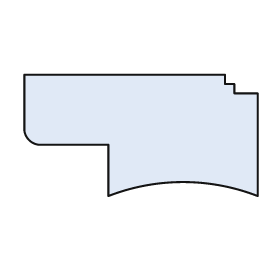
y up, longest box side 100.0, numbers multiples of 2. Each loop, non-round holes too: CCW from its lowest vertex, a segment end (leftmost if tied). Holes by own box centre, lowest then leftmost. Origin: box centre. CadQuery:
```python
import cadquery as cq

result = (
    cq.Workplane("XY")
    .moveTo(-14.0, -26.0)
    .threePointArc((18.0, -20.0), (50.0, -26.0))
    .lineTo(50.0, 18.0)
    .lineTo(40.0, 18.0)
    .lineTo(40.0, 22.0)
    .lineTo(36.0, 22.0)
    .lineTo(36.0, 26.0)
    .lineTo(-50.0, 26.0)
    .lineTo(-50.0, 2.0)
    .threePointArc((-48.0, -2.0), (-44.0, -4.0))
    .lineTo(-14.0, -4.0)
    .close()
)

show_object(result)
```